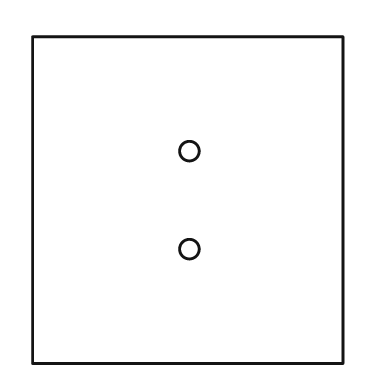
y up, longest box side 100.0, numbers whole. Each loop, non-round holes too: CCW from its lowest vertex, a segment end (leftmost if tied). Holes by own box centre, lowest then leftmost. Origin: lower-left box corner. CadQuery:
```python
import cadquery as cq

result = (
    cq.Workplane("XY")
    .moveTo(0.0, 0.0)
    .lineTo(95.0, 0.0)
    .lineTo(95.0, 100.0)
    .lineTo(0.0, 100.0)
    .close()
    .moveTo(48.0, 35.0)
    .circle(3.0)
    .moveTo(48.0, 65.0)
    .circle(3.0)
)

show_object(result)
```